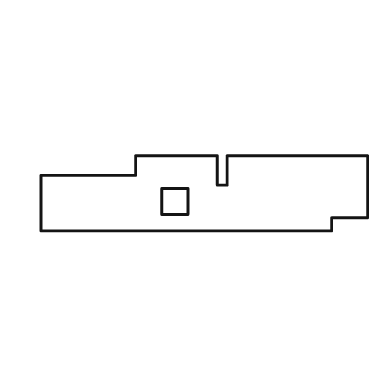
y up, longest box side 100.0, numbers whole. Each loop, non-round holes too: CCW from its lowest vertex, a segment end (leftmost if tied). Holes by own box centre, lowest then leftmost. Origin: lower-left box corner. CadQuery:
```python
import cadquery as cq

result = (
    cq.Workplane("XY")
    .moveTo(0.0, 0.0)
    .lineTo(89.0, 0.0)
    .lineTo(89.0, 4.0)
    .lineTo(100.0, 4.0)
    .lineTo(100.0, 23.0)
    .lineTo(57.0, 23.0)
    .lineTo(57.0, 14.0)
    .lineTo(54.0, 14.0)
    .lineTo(54.0, 23.0)
    .lineTo(29.0, 23.0)
    .lineTo(29.0, 17.0)
    .lineTo(0.0, 17.0)
    .close()
    .moveTo(37.0, 5.0)
    .lineTo(45.0, 5.0)
    .lineTo(45.0, 13.0)
    .lineTo(37.0, 13.0)
    .close()
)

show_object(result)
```